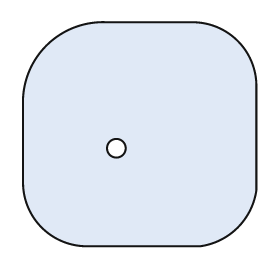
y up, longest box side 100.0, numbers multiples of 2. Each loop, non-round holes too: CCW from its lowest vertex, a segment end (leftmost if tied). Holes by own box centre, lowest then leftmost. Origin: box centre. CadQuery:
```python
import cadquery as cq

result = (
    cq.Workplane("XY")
    .moveTo(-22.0, -48.0)
    .lineTo(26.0, -48.0)
    .threePointArc((42.0, -40.0), (50.0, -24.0))
    .lineTo(50.0, 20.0)
    .threePointArc((42.0, 40.0), (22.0, 48.0))
    .lineTo(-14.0, 48.0)
    .threePointArc((-40.0, 38.0), (-50.0, 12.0))
    .lineTo(-50.0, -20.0)
    .threePointArc((-42.0, -40.0), (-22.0, -48.0))
    .close()
    .moveTo(-10.0, -6.0)
    .circle(4.0)
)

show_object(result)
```